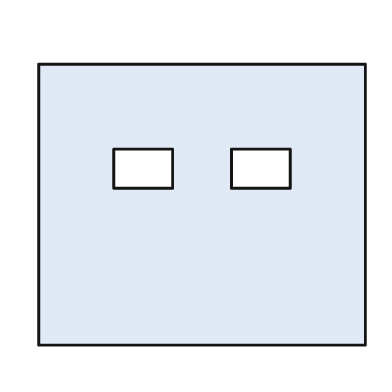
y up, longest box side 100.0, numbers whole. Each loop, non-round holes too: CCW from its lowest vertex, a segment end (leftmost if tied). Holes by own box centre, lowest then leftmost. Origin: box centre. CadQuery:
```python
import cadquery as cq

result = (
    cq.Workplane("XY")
    .moveTo(-50.0, -43.0)
    .lineTo(50.0, -43.0)
    .lineTo(50.0, 43.0)
    .lineTo(-50.0, 43.0)
    .close()
    .moveTo(-27.0, 5.0)
    .lineTo(-9.0, 5.0)
    .lineTo(-9.0, 17.0)
    .lineTo(-27.0, 17.0)
    .close()
    .moveTo(9.0, 5.0)
    .lineTo(27.0, 5.0)
    .lineTo(27.0, 17.0)
    .lineTo(9.0, 17.0)
    .close()
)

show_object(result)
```